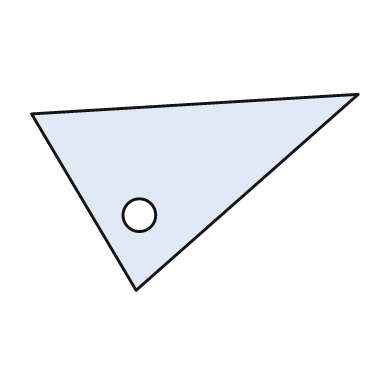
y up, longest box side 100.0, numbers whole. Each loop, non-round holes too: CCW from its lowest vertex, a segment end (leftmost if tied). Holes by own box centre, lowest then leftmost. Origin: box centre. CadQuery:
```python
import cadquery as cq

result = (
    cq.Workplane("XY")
    .moveTo(-18.0, -30.0)
    .lineTo(50.0, 30.0)
    .lineTo(-50.0, 24.0)
    .close()
    .moveTo(-17.0, -7.0)
    .circle(5.0)
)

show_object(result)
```